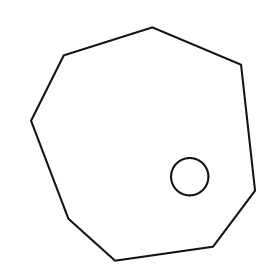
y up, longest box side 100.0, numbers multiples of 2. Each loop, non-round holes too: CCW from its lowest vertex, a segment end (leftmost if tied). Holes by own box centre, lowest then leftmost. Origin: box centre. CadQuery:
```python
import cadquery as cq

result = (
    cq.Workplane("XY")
    .moveTo(-12.0, -50.0)
    .lineTo(30.0, -44.0)
    .lineTo(48.0, -20.0)
    .lineTo(42.0, 34.0)
    .lineTo(4.0, 50.0)
    .lineTo(-34.0, 38.0)
    .lineTo(-48.0, 10.0)
    .lineTo(-32.0, -32.0)
    .close()
    .moveTo(20.0, -14.0)
    .circle(8.0)
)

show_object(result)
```